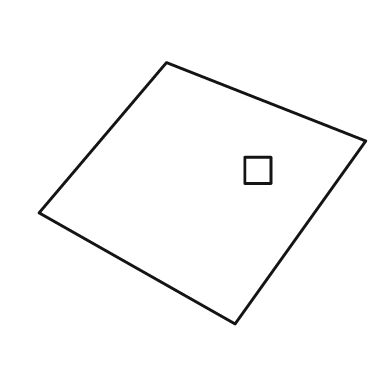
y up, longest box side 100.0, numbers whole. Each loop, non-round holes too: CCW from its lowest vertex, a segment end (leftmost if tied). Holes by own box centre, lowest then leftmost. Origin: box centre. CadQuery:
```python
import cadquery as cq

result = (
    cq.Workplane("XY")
    .moveTo(10.0, -40.0)
    .lineTo(50.0, 16.0)
    .lineTo(-11.0, 40.0)
    .lineTo(-50.0, -6.0)
    .close()
    .moveTo(13.0, 3.0)
    .lineTo(21.0, 3.0)
    .lineTo(21.0, 11.0)
    .lineTo(13.0, 11.0)
    .close()
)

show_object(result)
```